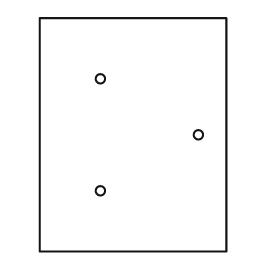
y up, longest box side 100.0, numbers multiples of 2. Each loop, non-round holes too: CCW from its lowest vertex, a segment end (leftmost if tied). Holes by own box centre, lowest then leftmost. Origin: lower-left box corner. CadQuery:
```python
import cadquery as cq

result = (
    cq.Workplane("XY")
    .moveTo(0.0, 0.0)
    .lineTo(80.0, 0.0)
    .lineTo(80.0, 100.0)
    .lineTo(0.0, 100.0)
    .close()
    .moveTo(26.0, 26.0)
    .circle(2.0)
    .moveTo(68.0, 50.0)
    .circle(2.0)
    .moveTo(26.0, 74.0)
    .circle(2.0)
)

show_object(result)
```